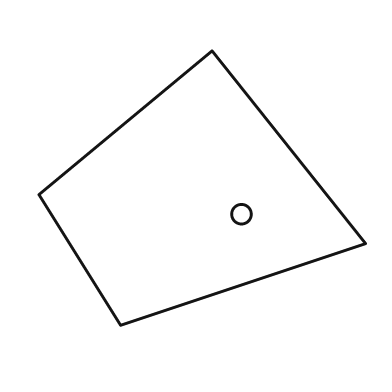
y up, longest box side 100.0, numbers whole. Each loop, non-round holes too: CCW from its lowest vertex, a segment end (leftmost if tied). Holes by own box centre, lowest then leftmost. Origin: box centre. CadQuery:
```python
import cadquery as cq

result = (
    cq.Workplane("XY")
    .moveTo(-25.0, -42.0)
    .lineTo(50.0, -17.0)
    .lineTo(3.0, 42.0)
    .lineTo(-50.0, -2.0)
    .close()
    .moveTo(12.0, -8.0)
    .circle(3.0)
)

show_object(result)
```